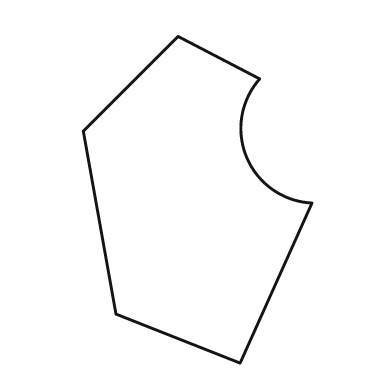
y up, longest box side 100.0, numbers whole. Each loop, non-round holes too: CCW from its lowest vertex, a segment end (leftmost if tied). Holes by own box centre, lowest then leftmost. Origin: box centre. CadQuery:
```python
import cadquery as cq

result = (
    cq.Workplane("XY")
    .moveTo(13.0, -50.0)
    .lineTo(35.0, -1.0)
    .threePointArc((15.0, 13.0), (19.0, 37.0))
    .lineTo(-6.0, 50.0)
    .lineTo(-35.0, 21.0)
    .lineTo(-25.0, -35.0)
    .close()
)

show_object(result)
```